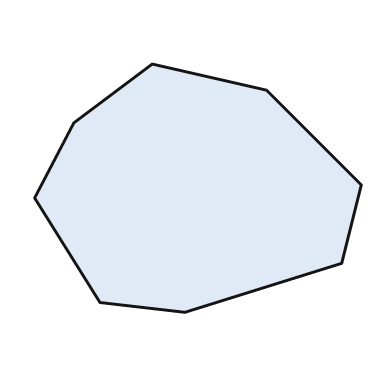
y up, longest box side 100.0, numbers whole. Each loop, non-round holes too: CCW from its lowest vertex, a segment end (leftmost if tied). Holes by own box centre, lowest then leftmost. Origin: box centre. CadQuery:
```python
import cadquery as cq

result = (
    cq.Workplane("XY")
    .moveTo(-4.0, -38.0)
    .lineTo(44.0, -23.0)
    .lineTo(50.0, 1.0)
    .lineTo(21.0, 30.0)
    .lineTo(-14.0, 38.0)
    .lineTo(-38.0, 20.0)
    .lineTo(-50.0, -3.0)
    .lineTo(-30.0, -35.0)
    .close()
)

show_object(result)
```